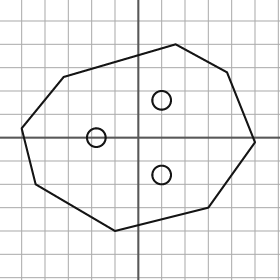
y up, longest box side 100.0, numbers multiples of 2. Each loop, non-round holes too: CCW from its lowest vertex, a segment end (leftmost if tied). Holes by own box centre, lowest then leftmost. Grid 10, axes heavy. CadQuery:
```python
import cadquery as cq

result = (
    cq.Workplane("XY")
    .moveTo(-10.0, -40.0)
    .lineTo(30.0, -30.0)
    .lineTo(50.0, -2.0)
    .lineTo(38.0, 28.0)
    .lineTo(16.0, 40.0)
    .lineTo(-32.0, 26.0)
    .lineTo(-50.0, 4.0)
    .lineTo(-44.0, -20.0)
    .close()
    .moveTo(10.0, -16.0)
    .circle(4.0)
    .moveTo(-18.0, 0.0)
    .circle(4.0)
    .moveTo(10.0, 16.0)
    .circle(4.0)
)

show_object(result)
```